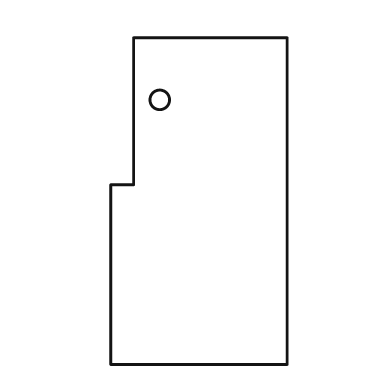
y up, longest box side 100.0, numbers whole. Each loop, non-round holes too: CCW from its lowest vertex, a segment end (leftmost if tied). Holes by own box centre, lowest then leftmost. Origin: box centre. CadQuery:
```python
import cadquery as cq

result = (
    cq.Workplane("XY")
    .moveTo(-27.0, -50.0)
    .lineTo(27.0, -50.0)
    .lineTo(27.0, 50.0)
    .lineTo(-20.0, 50.0)
    .lineTo(-20.0, 5.0)
    .lineTo(-27.0, 5.0)
    .close()
    .moveTo(-12.0, 31.0)
    .circle(3.0)
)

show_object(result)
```